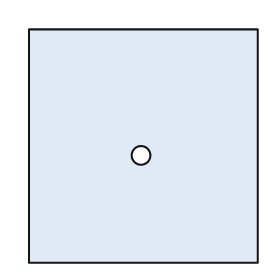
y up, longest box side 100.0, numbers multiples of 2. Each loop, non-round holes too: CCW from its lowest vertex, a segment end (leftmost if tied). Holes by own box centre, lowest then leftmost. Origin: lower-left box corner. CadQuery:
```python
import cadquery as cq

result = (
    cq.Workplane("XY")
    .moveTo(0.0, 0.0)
    .lineTo(98.0, 0.0)
    .lineTo(98.0, 100.0)
    .lineTo(0.0, 100.0)
    .close()
    .moveTo(48.0, 46.0)
    .circle(4.0)
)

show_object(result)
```